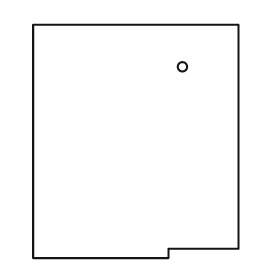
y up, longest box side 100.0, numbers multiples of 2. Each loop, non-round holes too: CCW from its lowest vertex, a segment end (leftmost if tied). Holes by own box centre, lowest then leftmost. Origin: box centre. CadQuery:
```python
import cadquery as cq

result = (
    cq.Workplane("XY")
    .moveTo(-44.0, -50.0)
    .lineTo(14.0, -50.0)
    .lineTo(14.0, -46.0)
    .lineTo(44.0, -46.0)
    .lineTo(44.0, 50.0)
    .lineTo(-44.0, 50.0)
    .close()
    .moveTo(20.0, 32.0)
    .circle(2.0)
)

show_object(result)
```